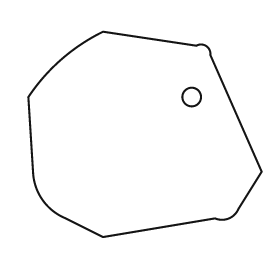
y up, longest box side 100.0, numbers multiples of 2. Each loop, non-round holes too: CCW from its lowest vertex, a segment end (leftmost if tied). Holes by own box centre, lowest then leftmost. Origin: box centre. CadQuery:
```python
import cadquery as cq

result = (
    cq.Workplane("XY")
    .moveTo(-18.0, -44.0)
    .lineTo(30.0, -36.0)
    .threePointArc((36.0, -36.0), (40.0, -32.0))
    .lineTo(50.0, -16.0)
    .lineTo(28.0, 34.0)
    .threePointArc((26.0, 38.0), (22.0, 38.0))
    .lineTo(-18.0, 44.0)
    .threePointArc((-36.0, 32.0), (-50.0, 16.0))
    .lineTo(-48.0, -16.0)
    .threePointArc((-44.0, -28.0), (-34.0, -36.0))
    .close()
    .moveTo(20.0, 16.0)
    .circle(4.0)
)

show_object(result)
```